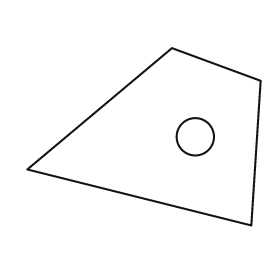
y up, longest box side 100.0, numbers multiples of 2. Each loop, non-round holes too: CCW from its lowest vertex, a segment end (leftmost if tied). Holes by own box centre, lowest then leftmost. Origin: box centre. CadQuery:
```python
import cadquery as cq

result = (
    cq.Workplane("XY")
    .moveTo(46.0, -38.0)
    .lineTo(50.0, 24.0)
    .lineTo(12.0, 38.0)
    .lineTo(-50.0, -14.0)
    .close()
    .moveTo(22.0, 0.0)
    .circle(8.0)
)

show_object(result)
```